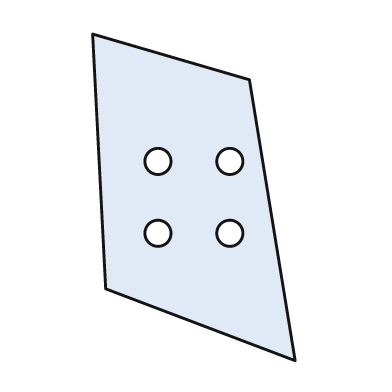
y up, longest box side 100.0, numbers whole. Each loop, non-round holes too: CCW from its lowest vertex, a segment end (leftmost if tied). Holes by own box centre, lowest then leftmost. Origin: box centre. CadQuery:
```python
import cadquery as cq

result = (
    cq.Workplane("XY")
    .moveTo(31.0, -50.0)
    .lineTo(17.0, 36.0)
    .lineTo(-31.0, 50.0)
    .lineTo(-27.0, -28.0)
    .close()
    .moveTo(-11.0, -11.0)
    .circle(4.0)
    .moveTo(11.0, -11.0)
    .circle(4.0)
    .moveTo(-11.0, 11.0)
    .circle(4.0)
    .moveTo(11.0, 11.0)
    .circle(4.0)
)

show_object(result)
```